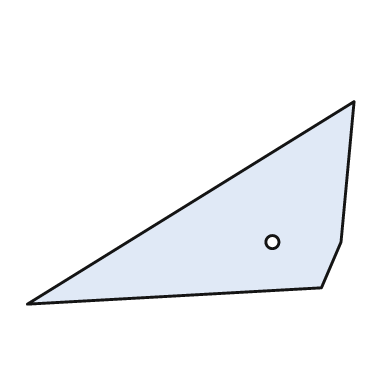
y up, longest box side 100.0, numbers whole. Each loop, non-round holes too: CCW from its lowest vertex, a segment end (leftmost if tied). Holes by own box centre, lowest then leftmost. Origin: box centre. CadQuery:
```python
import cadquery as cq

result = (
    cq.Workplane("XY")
    .moveTo(-50.0, -31.0)
    .lineTo(40.0, -26.0)
    .lineTo(46.0, -12.0)
    .lineTo(50.0, 31.0)
    .close()
    .moveTo(25.0, -12.0)
    .circle(2.0)
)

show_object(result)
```